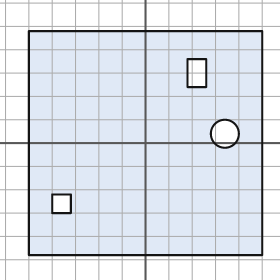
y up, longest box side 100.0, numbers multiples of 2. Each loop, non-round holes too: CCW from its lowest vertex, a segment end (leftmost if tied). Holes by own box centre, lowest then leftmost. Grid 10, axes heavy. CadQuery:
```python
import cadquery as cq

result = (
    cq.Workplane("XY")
    .moveTo(-50.0, -48.0)
    .lineTo(50.0, -48.0)
    .lineTo(50.0, 48.0)
    .lineTo(-50.0, 48.0)
    .close()
    .moveTo(-40.0, -30.0)
    .lineTo(-32.0, -30.0)
    .lineTo(-32.0, -22.0)
    .lineTo(-40.0, -22.0)
    .close()
    .moveTo(34.0, 4.0)
    .circle(6.0)
    .moveTo(18.0, 24.0)
    .lineTo(26.0, 24.0)
    .lineTo(26.0, 36.0)
    .lineTo(18.0, 36.0)
    .close()
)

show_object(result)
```